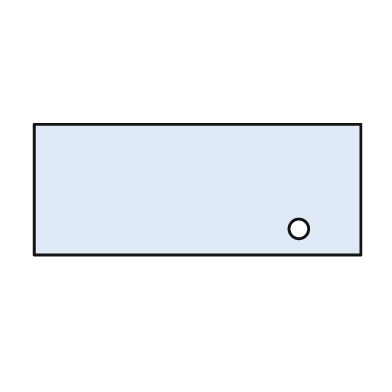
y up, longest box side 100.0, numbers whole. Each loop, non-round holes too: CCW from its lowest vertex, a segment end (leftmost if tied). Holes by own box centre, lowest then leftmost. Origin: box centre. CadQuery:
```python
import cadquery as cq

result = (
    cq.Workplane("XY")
    .moveTo(-50.0, -20.0)
    .lineTo(50.0, -20.0)
    .lineTo(50.0, 20.0)
    .lineTo(-50.0, 20.0)
    .close()
    .moveTo(31.0, -12.0)
    .circle(3.0)
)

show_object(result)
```